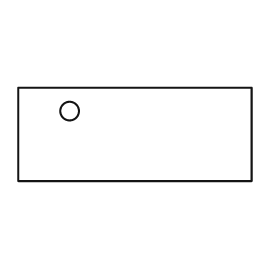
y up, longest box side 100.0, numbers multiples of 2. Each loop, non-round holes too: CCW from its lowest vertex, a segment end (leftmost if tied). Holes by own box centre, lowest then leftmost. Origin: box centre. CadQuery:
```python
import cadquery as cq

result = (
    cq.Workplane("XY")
    .moveTo(-50.0, -20.0)
    .lineTo(50.0, -20.0)
    .lineTo(50.0, 20.0)
    .lineTo(-50.0, 20.0)
    .close()
    .moveTo(-28.0, 10.0)
    .circle(4.0)
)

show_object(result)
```